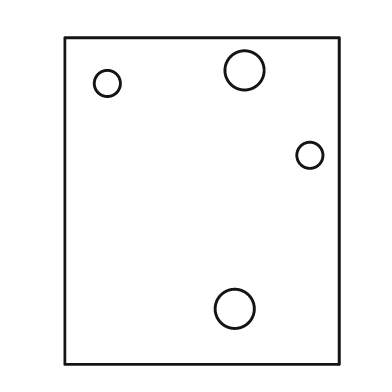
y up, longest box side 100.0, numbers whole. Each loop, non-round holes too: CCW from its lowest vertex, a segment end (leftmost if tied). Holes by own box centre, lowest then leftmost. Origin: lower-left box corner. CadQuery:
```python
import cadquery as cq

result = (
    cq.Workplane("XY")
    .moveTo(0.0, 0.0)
    .lineTo(84.0, 0.0)
    .lineTo(84.0, 100.0)
    .lineTo(0.0, 100.0)
    .close()
    .moveTo(52.0, 17.0)
    .circle(6.0)
    .moveTo(75.0, 64.0)
    .circle(4.0)
    .moveTo(13.0, 86.0)
    .circle(4.0)
    .moveTo(55.0, 90.0)
    .circle(6.0)
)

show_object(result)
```